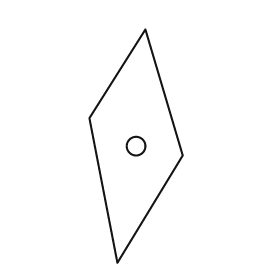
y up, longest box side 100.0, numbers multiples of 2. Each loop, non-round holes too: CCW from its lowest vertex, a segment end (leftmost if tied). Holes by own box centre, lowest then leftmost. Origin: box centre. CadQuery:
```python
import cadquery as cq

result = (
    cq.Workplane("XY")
    .moveTo(-8.0, -50.0)
    .lineTo(20.0, -4.0)
    .lineTo(4.0, 50.0)
    .lineTo(-20.0, 12.0)
    .close()
    .moveTo(0.0, 0.0)
    .circle(4.0)
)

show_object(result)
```